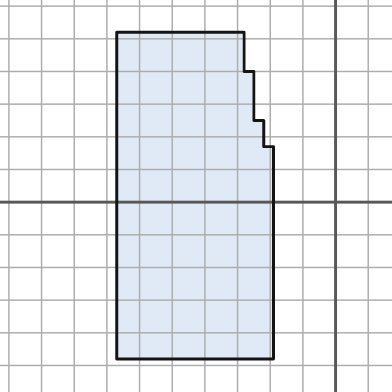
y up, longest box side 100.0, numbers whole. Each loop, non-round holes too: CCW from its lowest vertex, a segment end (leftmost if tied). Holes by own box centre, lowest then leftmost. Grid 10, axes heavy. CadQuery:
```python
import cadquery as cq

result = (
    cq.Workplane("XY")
    .moveTo(-67.0, -48.0)
    .lineTo(-19.0, -48.0)
    .lineTo(-19.0, 17.0)
    .lineTo(-22.0, 17.0)
    .lineTo(-22.0, 25.0)
    .lineTo(-25.0, 25.0)
    .lineTo(-25.0, 40.0)
    .lineTo(-28.0, 40.0)
    .lineTo(-28.0, 52.0)
    .lineTo(-67.0, 52.0)
    .close()
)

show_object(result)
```